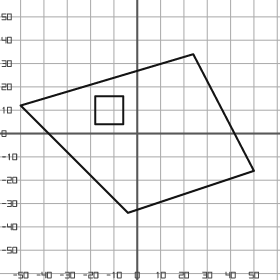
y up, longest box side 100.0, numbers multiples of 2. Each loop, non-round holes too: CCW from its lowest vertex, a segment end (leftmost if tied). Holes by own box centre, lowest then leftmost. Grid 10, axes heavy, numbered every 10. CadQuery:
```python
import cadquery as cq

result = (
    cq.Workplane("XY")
    .moveTo(-4.0, -34.0)
    .lineTo(50.0, -16.0)
    .lineTo(24.0, 34.0)
    .lineTo(-50.0, 12.0)
    .close()
    .moveTo(-18.0, 4.0)
    .lineTo(-6.0, 4.0)
    .lineTo(-6.0, 16.0)
    .lineTo(-18.0, 16.0)
    .close()
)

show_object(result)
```